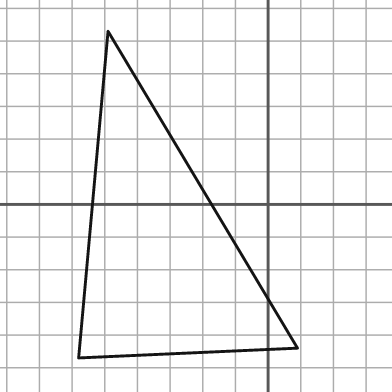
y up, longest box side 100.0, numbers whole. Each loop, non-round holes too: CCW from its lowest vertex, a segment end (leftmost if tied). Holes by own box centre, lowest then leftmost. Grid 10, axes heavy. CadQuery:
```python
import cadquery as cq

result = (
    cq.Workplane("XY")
    .moveTo(-58.0, -47.0)
    .lineTo(9.0, -44.0)
    .lineTo(-49.0, 53.0)
    .close()
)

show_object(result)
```